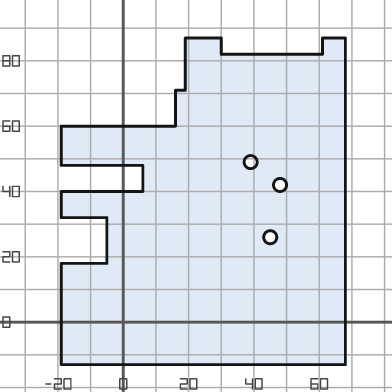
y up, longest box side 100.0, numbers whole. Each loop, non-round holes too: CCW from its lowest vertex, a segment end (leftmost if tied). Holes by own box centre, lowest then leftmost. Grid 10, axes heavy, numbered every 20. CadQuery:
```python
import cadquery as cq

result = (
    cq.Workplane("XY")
    .moveTo(-19.0, -13.0)
    .lineTo(68.0, -13.0)
    .lineTo(68.0, 87.0)
    .lineTo(61.0, 87.0)
    .lineTo(61.0, 82.0)
    .lineTo(30.0, 82.0)
    .lineTo(30.0, 87.0)
    .lineTo(19.0, 87.0)
    .lineTo(19.0, 71.0)
    .lineTo(16.0, 71.0)
    .lineTo(16.0, 60.0)
    .lineTo(-19.0, 60.0)
    .lineTo(-19.0, 48.0)
    .lineTo(6.0, 48.0)
    .lineTo(6.0, 40.0)
    .lineTo(-19.0, 40.0)
    .lineTo(-19.0, 32.0)
    .lineTo(-5.0, 32.0)
    .lineTo(-5.0, 18.0)
    .lineTo(-19.0, 18.0)
    .close()
    .moveTo(45.0, 26.0)
    .circle(2.0)
    .moveTo(48.0, 42.0)
    .circle(2.0)
    .moveTo(39.0, 49.0)
    .circle(2.0)
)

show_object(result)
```